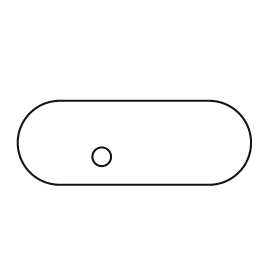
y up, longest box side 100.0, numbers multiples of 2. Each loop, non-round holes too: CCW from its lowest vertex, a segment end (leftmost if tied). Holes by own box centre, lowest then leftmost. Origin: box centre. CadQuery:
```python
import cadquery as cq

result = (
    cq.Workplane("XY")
    .moveTo(-32.0, -18.0)
    .lineTo(32.0, -18.0)
    .threePointArc((50.0, 0.0), (32.0, 18.0))
    .lineTo(-32.0, 18.0)
    .threePointArc((-50.0, 0.0), (-32.0, -18.0))
    .close()
    .moveTo(-14.0, -6.0)
    .circle(4.0)
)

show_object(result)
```